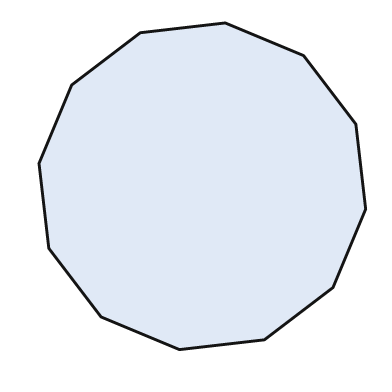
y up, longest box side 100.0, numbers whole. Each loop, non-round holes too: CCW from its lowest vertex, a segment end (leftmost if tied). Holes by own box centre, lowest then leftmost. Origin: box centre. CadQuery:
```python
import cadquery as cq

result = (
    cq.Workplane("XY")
    .moveTo(-7.0, -50.0)
    .lineTo(19.0, -47.0)
    .lineTo(40.0, -31.0)
    .lineTo(50.0, -7.0)
    .lineTo(47.0, 19.0)
    .lineTo(31.0, 40.0)
    .lineTo(7.0, 50.0)
    .lineTo(-19.0, 47.0)
    .lineTo(-40.0, 31.0)
    .lineTo(-50.0, 7.0)
    .lineTo(-47.0, -19.0)
    .lineTo(-31.0, -40.0)
    .close()
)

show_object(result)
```